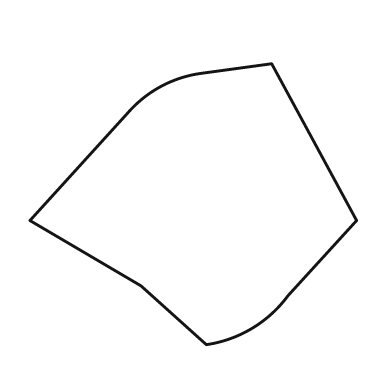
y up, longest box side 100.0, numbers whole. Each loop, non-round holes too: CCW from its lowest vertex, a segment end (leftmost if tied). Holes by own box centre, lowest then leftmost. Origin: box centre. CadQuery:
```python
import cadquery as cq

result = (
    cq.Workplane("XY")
    .moveTo(4.0, -43.0)
    .threePointArc((18.0, -38.0), (29.0, -28.0))
    .lineTo(50.0, -5.0)
    .lineTo(24.0, 43.0)
    .lineTo(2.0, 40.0)
    .threePointArc((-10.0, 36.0), (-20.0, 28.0))
    .lineTo(-50.0, -5.0)
    .lineTo(-16.0, -25.0)
    .close()
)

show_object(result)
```